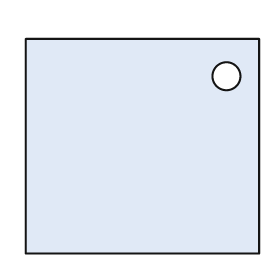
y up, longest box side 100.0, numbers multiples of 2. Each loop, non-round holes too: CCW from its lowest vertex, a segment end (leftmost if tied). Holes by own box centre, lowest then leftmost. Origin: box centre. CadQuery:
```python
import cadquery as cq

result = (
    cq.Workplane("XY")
    .moveTo(-50.0, -46.0)
    .lineTo(50.0, -46.0)
    .lineTo(50.0, 46.0)
    .lineTo(-50.0, 46.0)
    .close()
    .moveTo(36.0, 30.0)
    .circle(6.0)
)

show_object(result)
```